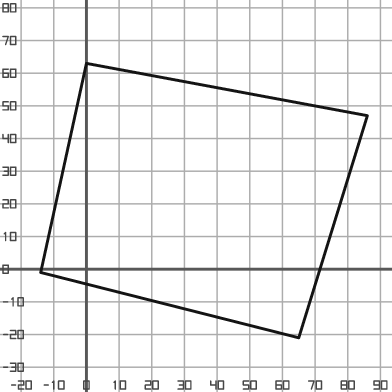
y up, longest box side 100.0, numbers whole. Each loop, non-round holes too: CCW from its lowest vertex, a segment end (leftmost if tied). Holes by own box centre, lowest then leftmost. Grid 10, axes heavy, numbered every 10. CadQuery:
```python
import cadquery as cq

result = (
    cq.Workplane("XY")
    .moveTo(65.0, -21.0)
    .lineTo(86.0, 47.0)
    .lineTo(0.0, 63.0)
    .lineTo(-14.0, -1.0)
    .close()
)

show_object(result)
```